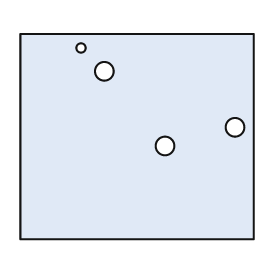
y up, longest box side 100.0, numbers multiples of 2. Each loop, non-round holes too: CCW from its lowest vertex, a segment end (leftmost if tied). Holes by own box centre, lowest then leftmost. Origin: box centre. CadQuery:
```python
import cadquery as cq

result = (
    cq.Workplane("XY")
    .moveTo(-50.0, -44.0)
    .lineTo(50.0, -44.0)
    .lineTo(50.0, 44.0)
    .lineTo(-50.0, 44.0)
    .close()
    .moveTo(12.0, -4.0)
    .circle(4.0)
    .moveTo(42.0, 4.0)
    .circle(4.0)
    .moveTo(-14.0, 28.0)
    .circle(4.0)
    .moveTo(-24.0, 38.0)
    .circle(2.0)
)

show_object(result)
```